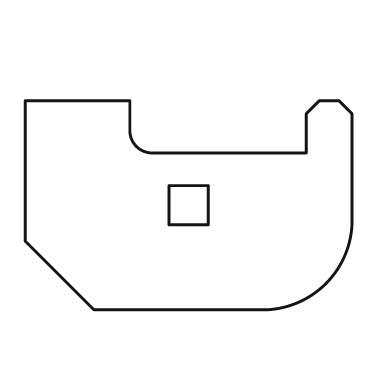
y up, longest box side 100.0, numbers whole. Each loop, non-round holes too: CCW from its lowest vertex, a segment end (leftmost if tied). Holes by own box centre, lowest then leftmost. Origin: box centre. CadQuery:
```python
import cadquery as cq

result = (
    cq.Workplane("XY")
    .moveTo(-29.0, -32.0)
    .lineTo(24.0, -32.0)
    .threePointArc((42.0, -24.0), (50.0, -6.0))
    .lineTo(50.0, 28.0)
    .lineTo(46.0, 32.0)
    .lineTo(40.0, 32.0)
    .lineTo(36.0, 28.0)
    .lineTo(36.0, 16.0)
    .lineTo(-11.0, 16.0)
    .threePointArc((-16.0, 18.0), (-18.0, 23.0))
    .lineTo(-18.0, 32.0)
    .lineTo(-50.0, 32.0)
    .lineTo(-50.0, -11.0)
    .close()
    .moveTo(-6.0, -6.0)
    .lineTo(6.0, -6.0)
    .lineTo(6.0, 6.0)
    .lineTo(-6.0, 6.0)
    .close()
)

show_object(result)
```